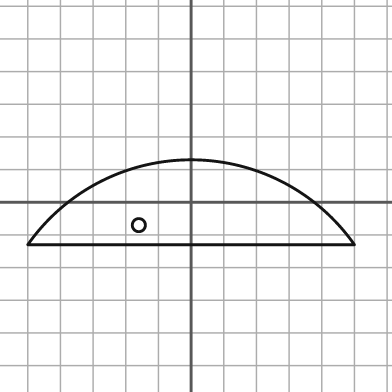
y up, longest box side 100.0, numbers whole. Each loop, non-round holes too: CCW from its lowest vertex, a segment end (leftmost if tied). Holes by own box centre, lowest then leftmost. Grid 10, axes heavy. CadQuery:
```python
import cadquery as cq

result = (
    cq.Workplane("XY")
    .moveTo(-50.0, -13.0)
    .lineTo(50.0, -13.0)
    .threePointArc((0.0, 13.0), (-50.0, -13.0))
    .close()
    .moveTo(-16.0, -7.0)
    .circle(2.0)
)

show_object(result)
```